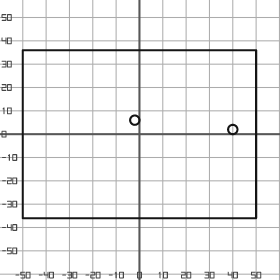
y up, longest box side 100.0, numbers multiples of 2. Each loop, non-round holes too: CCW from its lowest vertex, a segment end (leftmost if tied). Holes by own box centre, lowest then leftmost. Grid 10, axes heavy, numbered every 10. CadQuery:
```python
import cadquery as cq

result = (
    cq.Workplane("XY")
    .moveTo(-50.0, -36.0)
    .lineTo(50.0, -36.0)
    .lineTo(50.0, 36.0)
    .lineTo(-50.0, 36.0)
    .close()
    .moveTo(40.0, 2.0)
    .circle(2.0)
    .moveTo(-2.0, 6.0)
    .circle(2.0)
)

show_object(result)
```